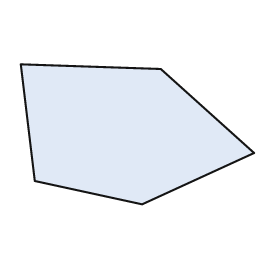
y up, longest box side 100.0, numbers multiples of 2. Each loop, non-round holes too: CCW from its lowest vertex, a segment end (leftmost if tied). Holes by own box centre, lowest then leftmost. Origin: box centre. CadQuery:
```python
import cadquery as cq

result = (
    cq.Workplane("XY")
    .moveTo(2.0, -30.0)
    .lineTo(50.0, -8.0)
    .lineTo(10.0, 28.0)
    .lineTo(-50.0, 30.0)
    .lineTo(-44.0, -20.0)
    .close()
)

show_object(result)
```